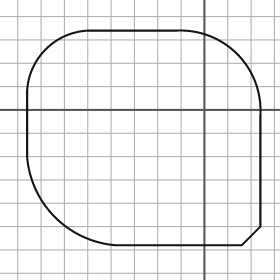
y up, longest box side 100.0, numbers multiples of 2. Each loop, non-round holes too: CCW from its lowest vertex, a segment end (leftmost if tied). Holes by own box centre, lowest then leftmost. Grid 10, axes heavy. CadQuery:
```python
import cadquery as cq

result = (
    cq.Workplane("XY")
    .moveTo(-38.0, -58.0)
    .lineTo(16.0, -58.0)
    .lineTo(24.0, -50.0)
    .lineTo(24.0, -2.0)
    .threePointArc((14.0, 24.0), (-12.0, 34.0))
    .lineTo(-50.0, 34.0)
    .threePointArc((-68.0, 26.0), (-76.0, 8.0))
    .lineTo(-76.0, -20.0)
    .threePointArc((-64.0, -46.0), (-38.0, -58.0))
    .close()
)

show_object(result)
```